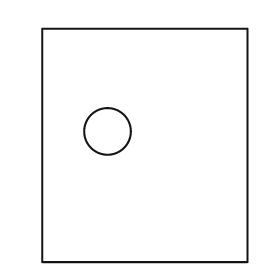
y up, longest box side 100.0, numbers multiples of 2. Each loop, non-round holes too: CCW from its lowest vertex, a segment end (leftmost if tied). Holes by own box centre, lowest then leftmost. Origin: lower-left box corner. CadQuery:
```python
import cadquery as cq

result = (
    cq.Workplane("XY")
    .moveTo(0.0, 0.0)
    .lineTo(88.0, 0.0)
    .lineTo(88.0, 100.0)
    .lineTo(0.0, 100.0)
    .close()
    .moveTo(28.0, 56.0)
    .circle(10.0)
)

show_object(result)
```